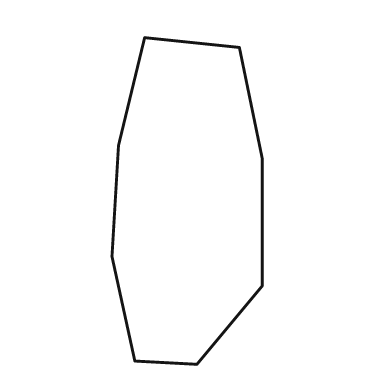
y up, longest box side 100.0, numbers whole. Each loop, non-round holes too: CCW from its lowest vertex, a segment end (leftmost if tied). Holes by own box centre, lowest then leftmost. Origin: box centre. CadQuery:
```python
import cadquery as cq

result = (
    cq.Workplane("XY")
    .moveTo(3.0, -50.0)
    .lineTo(23.0, -26.0)
    .lineTo(23.0, 13.0)
    .lineTo(16.0, 47.0)
    .lineTo(-13.0, 50.0)
    .lineTo(-21.0, 17.0)
    .lineTo(-23.0, -17.0)
    .lineTo(-16.0, -49.0)
    .close()
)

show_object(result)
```